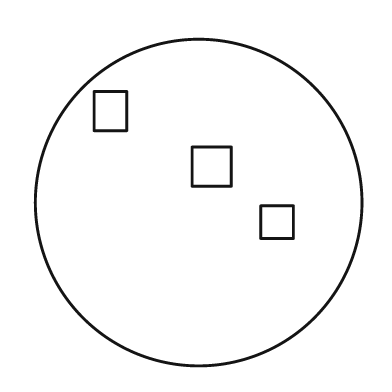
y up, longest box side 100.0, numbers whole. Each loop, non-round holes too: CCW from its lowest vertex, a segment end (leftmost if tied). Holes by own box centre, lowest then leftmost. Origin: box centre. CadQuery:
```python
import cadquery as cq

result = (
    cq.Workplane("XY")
    .moveTo(0.0, 0.0)
    .circle(50.0)
    .moveTo(19.0, -11.0)
    .lineTo(29.0, -11.0)
    .lineTo(29.0, -1.0)
    .lineTo(19.0, -1.0)
    .close()
    .moveTo(-2.0, 5.0)
    .lineTo(10.0, 5.0)
    .lineTo(10.0, 17.0)
    .lineTo(-2.0, 17.0)
    .close()
    .moveTo(-32.0, 22.0)
    .lineTo(-22.0, 22.0)
    .lineTo(-22.0, 34.0)
    .lineTo(-32.0, 34.0)
    .close()
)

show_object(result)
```